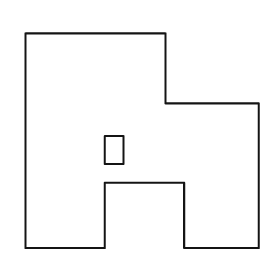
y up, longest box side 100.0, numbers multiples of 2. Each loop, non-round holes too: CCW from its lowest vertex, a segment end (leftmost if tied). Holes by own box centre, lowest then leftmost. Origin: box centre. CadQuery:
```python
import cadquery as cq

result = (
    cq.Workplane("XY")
    .moveTo(-50.0, -46.0)
    .lineTo(-16.0, -46.0)
    .lineTo(-16.0, -18.0)
    .lineTo(18.0, -18.0)
    .lineTo(18.0, -46.0)
    .lineTo(50.0, -46.0)
    .lineTo(50.0, 16.0)
    .lineTo(10.0, 16.0)
    .lineTo(10.0, 46.0)
    .lineTo(-50.0, 46.0)
    .close()
    .moveTo(-16.0, -10.0)
    .lineTo(-8.0, -10.0)
    .lineTo(-8.0, 2.0)
    .lineTo(-16.0, 2.0)
    .close()
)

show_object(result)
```